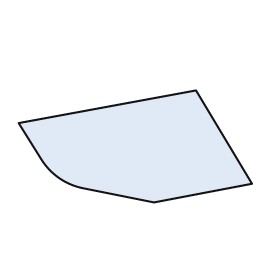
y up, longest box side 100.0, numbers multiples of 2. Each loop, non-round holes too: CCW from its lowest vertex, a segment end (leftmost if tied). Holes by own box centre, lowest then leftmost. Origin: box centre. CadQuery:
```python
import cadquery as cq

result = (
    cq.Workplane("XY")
    .moveTo(8.0, -24.0)
    .lineTo(50.0, -16.0)
    .lineTo(26.0, 24.0)
    .lineTo(-50.0, 10.0)
    .lineTo(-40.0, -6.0)
    .threePointArc((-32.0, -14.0), (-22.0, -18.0))
    .close()
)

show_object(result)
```